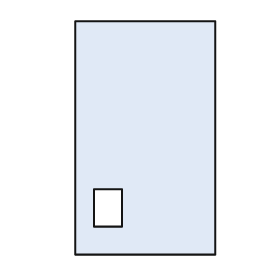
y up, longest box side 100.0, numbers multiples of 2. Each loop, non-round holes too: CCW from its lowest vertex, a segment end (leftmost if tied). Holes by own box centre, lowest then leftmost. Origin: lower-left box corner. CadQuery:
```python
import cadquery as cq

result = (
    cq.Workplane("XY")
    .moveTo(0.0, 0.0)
    .lineTo(60.0, 0.0)
    .lineTo(60.0, 100.0)
    .lineTo(0.0, 100.0)
    .close()
    .moveTo(8.0, 12.0)
    .lineTo(20.0, 12.0)
    .lineTo(20.0, 28.0)
    .lineTo(8.0, 28.0)
    .close()
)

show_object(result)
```